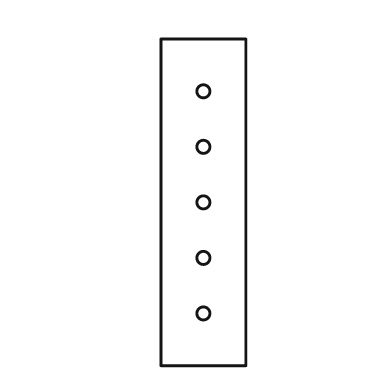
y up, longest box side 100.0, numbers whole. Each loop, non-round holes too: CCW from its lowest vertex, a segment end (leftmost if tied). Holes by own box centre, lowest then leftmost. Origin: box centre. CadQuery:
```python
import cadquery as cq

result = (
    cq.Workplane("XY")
    .moveTo(-13.0, -50.0)
    .lineTo(13.0, -50.0)
    .lineTo(13.0, 50.0)
    .lineTo(-13.0, 50.0)
    .close()
    .moveTo(0.0, -34.0)
    .circle(2.0)
    .moveTo(0.0, -17.0)
    .circle(2.0)
    .moveTo(0.0, 0.0)
    .circle(2.0)
    .moveTo(0.0, 17.0)
    .circle(2.0)
    .moveTo(0.0, 34.0)
    .circle(2.0)
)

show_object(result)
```